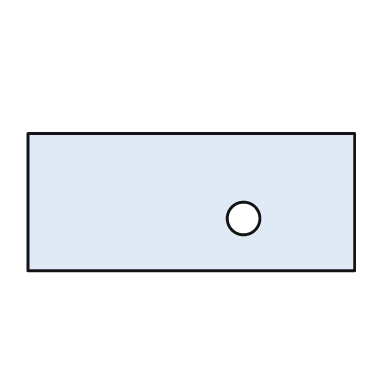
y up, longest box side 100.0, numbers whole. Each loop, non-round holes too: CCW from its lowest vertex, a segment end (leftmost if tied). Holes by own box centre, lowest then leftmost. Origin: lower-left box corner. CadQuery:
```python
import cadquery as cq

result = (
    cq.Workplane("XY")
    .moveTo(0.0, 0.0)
    .lineTo(100.0, 0.0)
    .lineTo(100.0, 42.0)
    .lineTo(0.0, 42.0)
    .close()
    .moveTo(66.0, 16.0)
    .circle(5.0)
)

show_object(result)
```